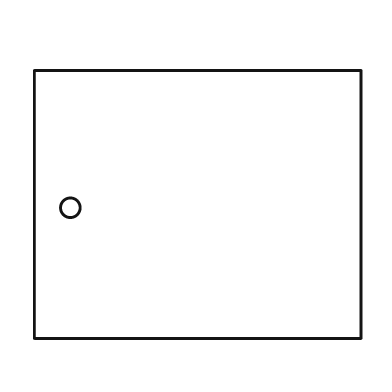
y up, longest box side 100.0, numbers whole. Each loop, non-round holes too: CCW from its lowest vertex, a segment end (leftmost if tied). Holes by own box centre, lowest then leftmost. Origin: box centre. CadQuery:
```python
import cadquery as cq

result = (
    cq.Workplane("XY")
    .moveTo(-50.0, -41.0)
    .lineTo(50.0, -41.0)
    .lineTo(50.0, 41.0)
    .lineTo(-50.0, 41.0)
    .close()
    .moveTo(-39.0, -1.0)
    .circle(3.0)
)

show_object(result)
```